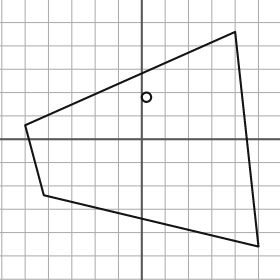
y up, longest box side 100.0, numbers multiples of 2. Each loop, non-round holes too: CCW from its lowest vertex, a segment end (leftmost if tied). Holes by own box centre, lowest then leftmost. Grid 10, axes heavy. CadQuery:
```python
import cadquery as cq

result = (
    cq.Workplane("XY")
    .moveTo(50.0, -46.0)
    .lineTo(40.0, 46.0)
    .lineTo(-50.0, 6.0)
    .lineTo(-42.0, -24.0)
    .close()
    .moveTo(2.0, 18.0)
    .circle(2.0)
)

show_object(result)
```